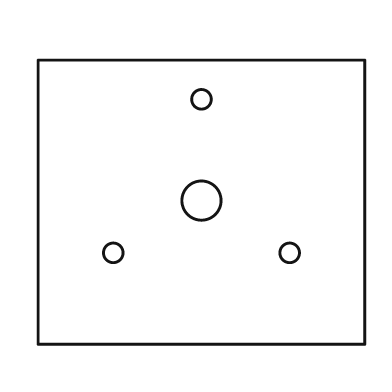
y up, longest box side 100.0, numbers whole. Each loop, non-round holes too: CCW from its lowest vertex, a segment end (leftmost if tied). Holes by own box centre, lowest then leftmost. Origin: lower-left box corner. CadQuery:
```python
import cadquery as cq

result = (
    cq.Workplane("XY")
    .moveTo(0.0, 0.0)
    .lineTo(100.0, 0.0)
    .lineTo(100.0, 87.0)
    .lineTo(0.0, 87.0)
    .close()
    .moveTo(23.0, 28.0)
    .circle(3.0)
    .moveTo(77.0, 28.0)
    .circle(3.0)
    .moveTo(50.0, 44.0)
    .circle(6.0)
    .moveTo(50.0, 75.0)
    .circle(3.0)
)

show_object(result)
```